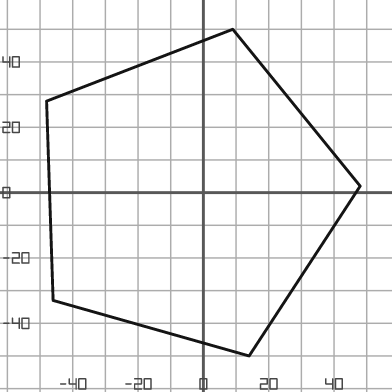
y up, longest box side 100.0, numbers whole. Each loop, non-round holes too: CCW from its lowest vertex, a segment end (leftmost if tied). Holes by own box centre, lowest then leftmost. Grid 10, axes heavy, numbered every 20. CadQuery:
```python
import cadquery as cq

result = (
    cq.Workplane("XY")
    .moveTo(14.0, -50.0)
    .lineTo(48.0, 2.0)
    .lineTo(9.0, 50.0)
    .lineTo(-48.0, 28.0)
    .lineTo(-46.0, -33.0)
    .close()
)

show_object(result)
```